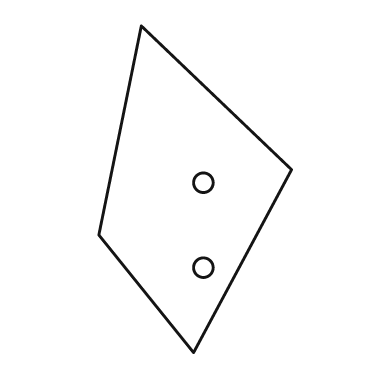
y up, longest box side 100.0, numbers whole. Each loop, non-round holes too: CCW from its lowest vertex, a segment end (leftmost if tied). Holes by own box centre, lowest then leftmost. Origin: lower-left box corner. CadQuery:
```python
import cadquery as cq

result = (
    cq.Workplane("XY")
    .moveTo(29.0, 0.0)
    .lineTo(59.0, 56.0)
    .lineTo(13.0, 100.0)
    .lineTo(0.0, 36.0)
    .close()
    .moveTo(32.0, 26.0)
    .circle(3.0)
    .moveTo(32.0, 52.0)
    .circle(3.0)
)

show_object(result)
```